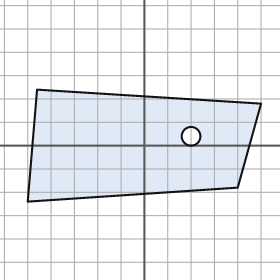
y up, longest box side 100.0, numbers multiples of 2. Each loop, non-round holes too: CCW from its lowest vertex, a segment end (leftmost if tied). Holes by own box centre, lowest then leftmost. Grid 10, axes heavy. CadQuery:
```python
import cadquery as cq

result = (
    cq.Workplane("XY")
    .moveTo(-50.0, -24.0)
    .lineTo(40.0, -18.0)
    .lineTo(50.0, 18.0)
    .lineTo(-46.0, 24.0)
    .close()
    .moveTo(20.0, 4.0)
    .circle(4.0)
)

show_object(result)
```